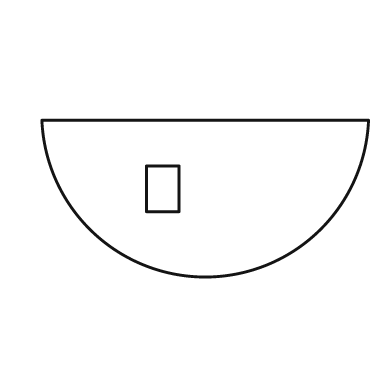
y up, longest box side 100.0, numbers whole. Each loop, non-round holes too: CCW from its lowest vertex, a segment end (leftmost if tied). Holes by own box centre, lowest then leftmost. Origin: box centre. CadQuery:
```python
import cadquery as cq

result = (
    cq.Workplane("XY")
    .moveTo(-50.0, 24.0)
    .threePointArc((0.0, -24.0), (50.0, 24.0))
    .close()
    .moveTo(-18.0, -4.0)
    .lineTo(-8.0, -4.0)
    .lineTo(-8.0, 10.0)
    .lineTo(-18.0, 10.0)
    .close()
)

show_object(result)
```